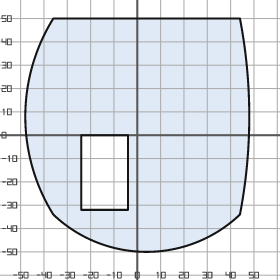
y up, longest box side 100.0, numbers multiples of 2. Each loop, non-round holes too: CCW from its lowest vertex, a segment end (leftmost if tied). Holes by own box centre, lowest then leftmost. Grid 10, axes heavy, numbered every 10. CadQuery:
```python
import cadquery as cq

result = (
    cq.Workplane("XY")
    .moveTo(-36.0, -34.0)
    .threePointArc((4.0, -50.0), (44.0, -34.0))
    .threePointArc((48.0, 8.0), (44.0, 50.0))
    .lineTo(-36.0, 50.0)
    .threePointArc((-48.0, 8.0), (-36.0, -34.0))
    .close()
    .moveTo(-24.0, -32.0)
    .lineTo(-4.0, -32.0)
    .lineTo(-4.0, 0.0)
    .lineTo(-24.0, 0.0)
    .close()
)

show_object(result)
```